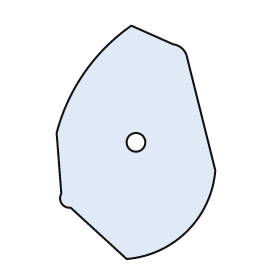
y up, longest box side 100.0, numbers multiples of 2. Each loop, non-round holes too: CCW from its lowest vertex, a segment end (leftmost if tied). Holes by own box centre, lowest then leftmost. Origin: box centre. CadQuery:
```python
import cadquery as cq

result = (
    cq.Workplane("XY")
    .moveTo(-4.0, -50.0)
    .threePointArc((22.0, -38.0), (34.0, -12.0))
    .lineTo(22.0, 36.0)
    .threePointArc((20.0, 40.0), (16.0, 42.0))
    .lineTo(-2.0, 50.0)
    .threePointArc((-22.0, 30.0), (-34.0, 4.0))
    .lineTo(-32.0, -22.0)
    .threePointArc((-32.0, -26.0), (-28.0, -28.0))
    .close()
    .moveTo(0.0, 0.0)
    .circle(4.0)
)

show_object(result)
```